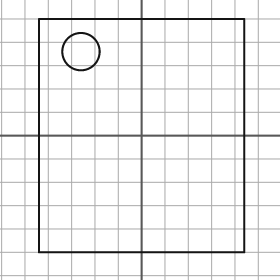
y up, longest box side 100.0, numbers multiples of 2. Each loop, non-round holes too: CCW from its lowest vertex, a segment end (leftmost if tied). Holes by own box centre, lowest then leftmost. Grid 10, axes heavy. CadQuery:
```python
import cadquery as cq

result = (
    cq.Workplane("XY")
    .moveTo(-44.0, -50.0)
    .lineTo(44.0, -50.0)
    .lineTo(44.0, 50.0)
    .lineTo(-44.0, 50.0)
    .close()
    .moveTo(-26.0, 36.0)
    .circle(8.0)
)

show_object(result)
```